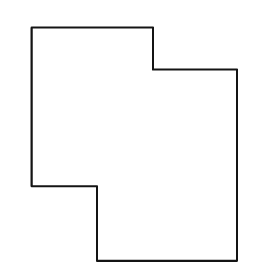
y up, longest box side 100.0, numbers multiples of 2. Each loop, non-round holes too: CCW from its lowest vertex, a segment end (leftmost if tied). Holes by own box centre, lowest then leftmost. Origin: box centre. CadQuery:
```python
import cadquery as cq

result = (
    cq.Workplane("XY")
    .moveTo(-16.0, -50.0)
    .lineTo(44.0, -50.0)
    .lineTo(44.0, 32.0)
    .lineTo(8.0, 32.0)
    .lineTo(8.0, 50.0)
    .lineTo(-44.0, 50.0)
    .lineTo(-44.0, -18.0)
    .lineTo(-16.0, -18.0)
    .close()
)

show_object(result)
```